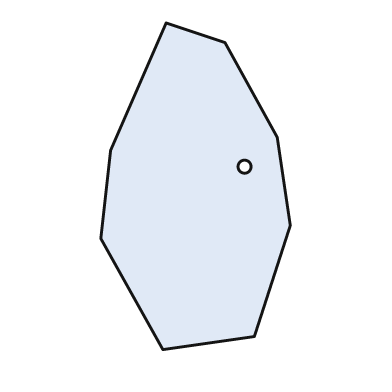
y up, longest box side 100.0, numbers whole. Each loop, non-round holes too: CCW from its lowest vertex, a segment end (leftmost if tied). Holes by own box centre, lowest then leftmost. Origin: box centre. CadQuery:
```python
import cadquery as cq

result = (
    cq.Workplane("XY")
    .moveTo(-10.0, -50.0)
    .lineTo(18.0, -46.0)
    .lineTo(29.0, -12.0)
    .lineTo(25.0, 15.0)
    .lineTo(9.0, 44.0)
    .lineTo(-9.0, 50.0)
    .lineTo(-26.0, 11.0)
    .lineTo(-29.0, -16.0)
    .close()
    .moveTo(15.0, 6.0)
    .circle(2.0)
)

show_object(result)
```